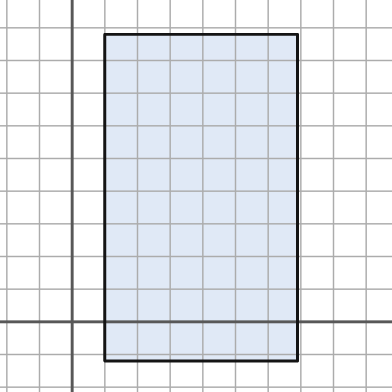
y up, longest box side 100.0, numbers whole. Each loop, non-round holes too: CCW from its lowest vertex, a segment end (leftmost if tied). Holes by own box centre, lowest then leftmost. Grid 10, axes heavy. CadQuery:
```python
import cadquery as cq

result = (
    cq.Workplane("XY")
    .moveTo(10.0, -12.0)
    .lineTo(69.0, -12.0)
    .lineTo(69.0, 88.0)
    .lineTo(10.0, 88.0)
    .close()
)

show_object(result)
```